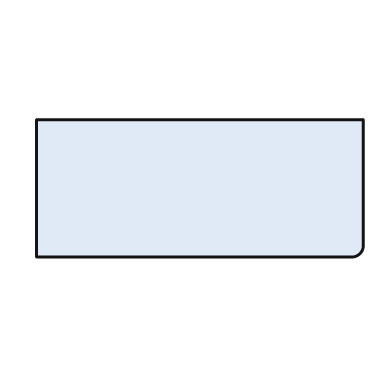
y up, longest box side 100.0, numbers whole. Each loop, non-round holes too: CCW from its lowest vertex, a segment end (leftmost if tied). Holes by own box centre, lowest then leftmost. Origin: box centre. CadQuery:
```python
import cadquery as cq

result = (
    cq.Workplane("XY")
    .moveTo(-50.0, -21.0)
    .lineTo(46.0, -21.0)
    .threePointArc((49.0, -20.0), (50.0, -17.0))
    .lineTo(50.0, 21.0)
    .lineTo(-50.0, 21.0)
    .close()
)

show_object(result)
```